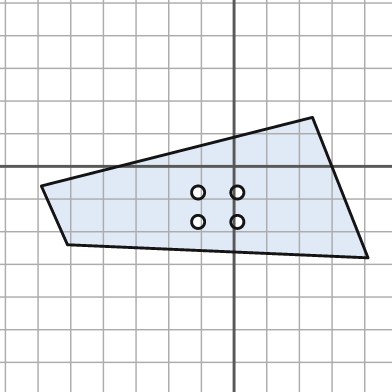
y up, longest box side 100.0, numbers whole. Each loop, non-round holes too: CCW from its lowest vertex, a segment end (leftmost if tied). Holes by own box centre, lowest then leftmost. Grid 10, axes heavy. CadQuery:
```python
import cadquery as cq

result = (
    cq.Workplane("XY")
    .moveTo(41.0, -28.0)
    .lineTo(24.0, 15.0)
    .lineTo(-59.0, -6.0)
    .lineTo(-51.0, -24.0)
    .close()
    .moveTo(-11.0, -17.0)
    .circle(2.0)
    .moveTo(1.0, -17.0)
    .circle(2.0)
    .moveTo(-11.0, -8.0)
    .circle(2.0)
    .moveTo(1.0, -8.0)
    .circle(2.0)
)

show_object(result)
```